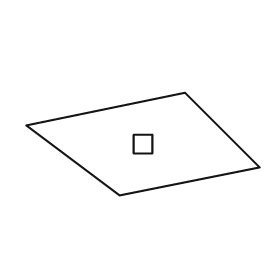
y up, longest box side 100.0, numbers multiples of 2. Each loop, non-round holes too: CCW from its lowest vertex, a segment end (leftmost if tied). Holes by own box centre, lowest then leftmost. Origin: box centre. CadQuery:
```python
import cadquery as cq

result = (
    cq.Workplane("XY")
    .moveTo(-10.0, -22.0)
    .lineTo(50.0, -10.0)
    .lineTo(18.0, 22.0)
    .lineTo(-50.0, 8.0)
    .close()
    .moveTo(-4.0, -4.0)
    .lineTo(4.0, -4.0)
    .lineTo(4.0, 4.0)
    .lineTo(-4.0, 4.0)
    .close()
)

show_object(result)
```